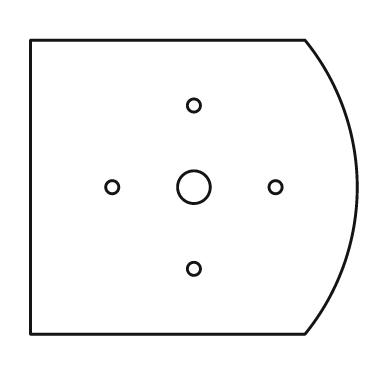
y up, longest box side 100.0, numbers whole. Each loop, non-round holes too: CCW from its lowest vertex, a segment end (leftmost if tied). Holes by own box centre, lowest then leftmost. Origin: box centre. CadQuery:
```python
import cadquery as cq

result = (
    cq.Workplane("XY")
    .moveTo(-50.0, -45.0)
    .lineTo(34.0, -45.0)
    .threePointArc((50.0, 0.0), (34.0, 45.0))
    .lineTo(-50.0, 45.0)
    .close()
    .moveTo(0.0, -25.0)
    .circle(2.0)
    .moveTo(-25.0, 0.0)
    .circle(2.0)
    .moveTo(0.0, 0.0)
    .circle(5.0)
    .moveTo(25.0, 0.0)
    .circle(2.0)
    .moveTo(0.0, 25.0)
    .circle(2.0)
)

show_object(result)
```